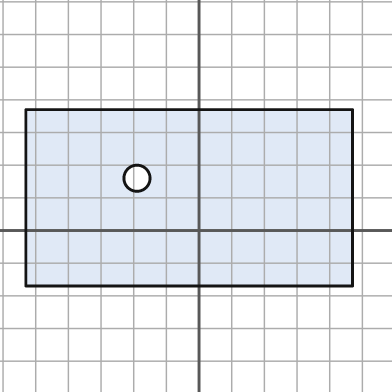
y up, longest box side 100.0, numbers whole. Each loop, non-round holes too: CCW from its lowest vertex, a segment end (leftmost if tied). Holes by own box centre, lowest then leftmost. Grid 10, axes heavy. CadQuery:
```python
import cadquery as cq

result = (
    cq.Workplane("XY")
    .moveTo(-53.0, -17.0)
    .lineTo(47.0, -17.0)
    .lineTo(47.0, 37.0)
    .lineTo(-53.0, 37.0)
    .close()
    .moveTo(-19.0, 16.0)
    .circle(4.0)
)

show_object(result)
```